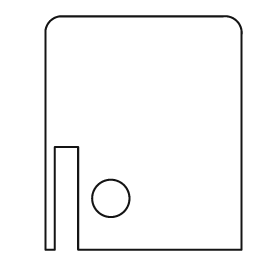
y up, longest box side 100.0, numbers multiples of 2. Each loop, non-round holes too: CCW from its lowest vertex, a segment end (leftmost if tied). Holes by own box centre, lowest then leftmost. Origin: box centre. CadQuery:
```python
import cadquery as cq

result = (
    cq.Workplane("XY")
    .moveTo(-42.0, -50.0)
    .lineTo(-38.0, -50.0)
    .lineTo(-38.0, -6.0)
    .lineTo(-28.0, -6.0)
    .lineTo(-28.0, -50.0)
    .lineTo(42.0, -50.0)
    .lineTo(42.0, 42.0)
    .threePointArc((40.0, 48.0), (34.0, 50.0))
    .lineTo(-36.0, 50.0)
    .threePointArc((-40.0, 48.0), (-42.0, 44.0))
    .close()
    .moveTo(-14.0, -28.0)
    .circle(8.0)
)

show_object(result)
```